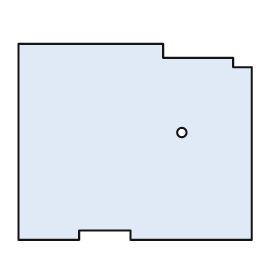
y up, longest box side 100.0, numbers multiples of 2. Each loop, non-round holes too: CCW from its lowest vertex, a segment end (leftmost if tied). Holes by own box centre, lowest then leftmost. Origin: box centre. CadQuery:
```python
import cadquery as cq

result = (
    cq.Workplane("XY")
    .moveTo(-50.0, -42.0)
    .lineTo(-24.0, -42.0)
    .lineTo(-24.0, -38.0)
    .lineTo(-2.0, -38.0)
    .lineTo(-2.0, -42.0)
    .lineTo(50.0, -42.0)
    .lineTo(50.0, 32.0)
    .lineTo(42.0, 32.0)
    .lineTo(42.0, 36.0)
    .lineTo(12.0, 36.0)
    .lineTo(12.0, 42.0)
    .lineTo(-50.0, 42.0)
    .close()
    .moveTo(20.0, 4.0)
    .circle(2.0)
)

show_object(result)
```